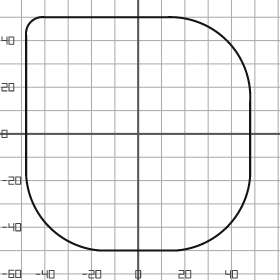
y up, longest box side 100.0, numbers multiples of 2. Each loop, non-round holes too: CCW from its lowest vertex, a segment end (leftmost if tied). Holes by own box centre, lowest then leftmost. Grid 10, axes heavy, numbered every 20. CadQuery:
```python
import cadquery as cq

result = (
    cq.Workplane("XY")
    .moveTo(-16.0, -50.0)
    .lineTo(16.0, -50.0)
    .threePointArc((38.0, -40.0), (48.0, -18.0))
    .lineTo(48.0, 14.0)
    .threePointArc((38.0, 40.0), (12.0, 50.0))
    .lineTo(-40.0, 50.0)
    .threePointArc((-46.0, 48.0), (-48.0, 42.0))
    .lineTo(-48.0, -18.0)
    .threePointArc((-38.0, -40.0), (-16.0, -50.0))
    .close()
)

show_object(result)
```